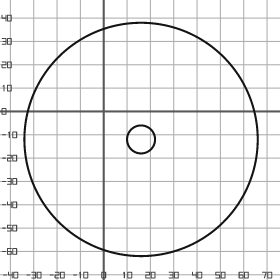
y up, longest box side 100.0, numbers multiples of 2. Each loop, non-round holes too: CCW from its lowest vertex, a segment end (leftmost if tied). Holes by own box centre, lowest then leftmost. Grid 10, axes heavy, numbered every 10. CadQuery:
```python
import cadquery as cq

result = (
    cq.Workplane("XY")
    .moveTo(16.0, -12.0)
    .circle(50.0)
    .moveTo(16.0, -12.0)
    .circle(6.0)
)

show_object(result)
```